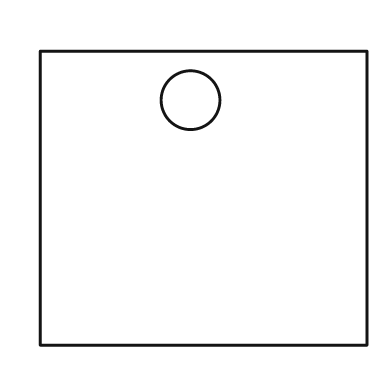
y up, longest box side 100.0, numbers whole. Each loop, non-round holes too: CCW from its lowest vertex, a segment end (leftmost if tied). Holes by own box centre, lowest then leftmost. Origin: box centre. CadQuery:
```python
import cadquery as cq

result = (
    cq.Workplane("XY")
    .moveTo(-50.0, -45.0)
    .lineTo(50.0, -45.0)
    .lineTo(50.0, 45.0)
    .lineTo(-50.0, 45.0)
    .close()
    .moveTo(-4.0, 30.0)
    .circle(9.0)
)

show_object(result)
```